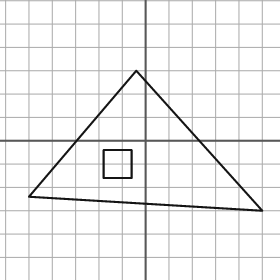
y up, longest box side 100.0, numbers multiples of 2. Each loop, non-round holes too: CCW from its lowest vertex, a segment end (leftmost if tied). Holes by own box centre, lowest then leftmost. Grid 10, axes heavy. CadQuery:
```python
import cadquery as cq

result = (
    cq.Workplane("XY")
    .moveTo(50.0, -30.0)
    .lineTo(-4.0, 30.0)
    .lineTo(-50.0, -24.0)
    .close()
    .moveTo(-18.0, -16.0)
    .lineTo(-6.0, -16.0)
    .lineTo(-6.0, -4.0)
    .lineTo(-18.0, -4.0)
    .close()
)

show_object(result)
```